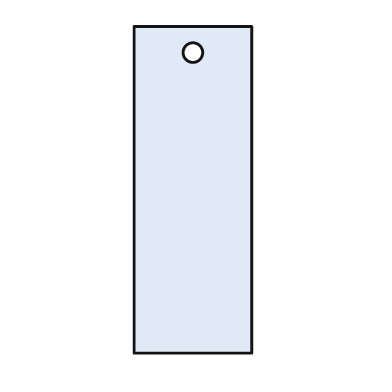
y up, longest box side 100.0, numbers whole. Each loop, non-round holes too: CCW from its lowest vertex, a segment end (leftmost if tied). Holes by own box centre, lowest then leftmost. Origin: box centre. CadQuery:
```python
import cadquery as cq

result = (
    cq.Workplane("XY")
    .moveTo(-18.0, -50.0)
    .lineTo(18.0, -50.0)
    .lineTo(18.0, 50.0)
    .lineTo(-18.0, 50.0)
    .close()
    .moveTo(0.0, 42.0)
    .circle(3.0)
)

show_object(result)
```